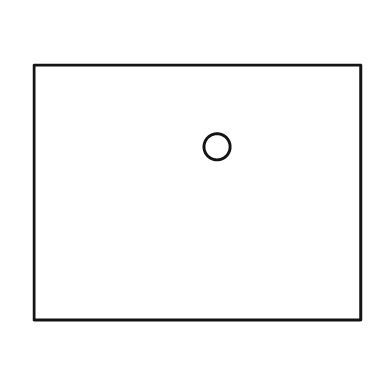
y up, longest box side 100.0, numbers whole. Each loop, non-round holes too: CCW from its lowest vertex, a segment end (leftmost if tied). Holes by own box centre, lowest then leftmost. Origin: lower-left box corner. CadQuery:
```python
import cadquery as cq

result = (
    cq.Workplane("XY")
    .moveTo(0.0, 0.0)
    .lineTo(100.0, 0.0)
    .lineTo(100.0, 78.0)
    .lineTo(0.0, 78.0)
    .close()
    .moveTo(56.0, 53.0)
    .circle(4.0)
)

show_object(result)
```